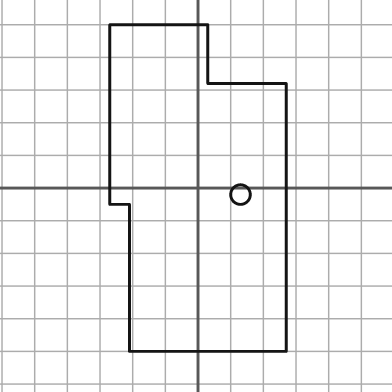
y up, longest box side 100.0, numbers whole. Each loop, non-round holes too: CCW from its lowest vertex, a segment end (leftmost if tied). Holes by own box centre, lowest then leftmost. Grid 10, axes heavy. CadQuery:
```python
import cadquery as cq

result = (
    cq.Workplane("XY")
    .moveTo(-21.0, -50.0)
    .lineTo(27.0, -50.0)
    .lineTo(27.0, 32.0)
    .lineTo(3.0, 32.0)
    .lineTo(3.0, 50.0)
    .lineTo(-27.0, 50.0)
    .lineTo(-27.0, -5.0)
    .lineTo(-21.0, -5.0)
    .close()
    .moveTo(13.0, -2.0)
    .circle(3.0)
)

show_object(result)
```